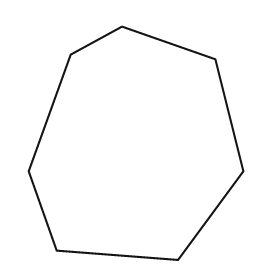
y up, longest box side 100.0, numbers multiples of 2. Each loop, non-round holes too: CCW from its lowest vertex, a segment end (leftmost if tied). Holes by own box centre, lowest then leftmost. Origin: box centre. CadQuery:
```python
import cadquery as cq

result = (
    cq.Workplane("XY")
    .moveTo(18.0, -50.0)
    .lineTo(46.0, -12.0)
    .lineTo(34.0, 36.0)
    .lineTo(-6.0, 50.0)
    .lineTo(-28.0, 38.0)
    .lineTo(-46.0, -12.0)
    .lineTo(-34.0, -46.0)
    .close()
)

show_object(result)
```